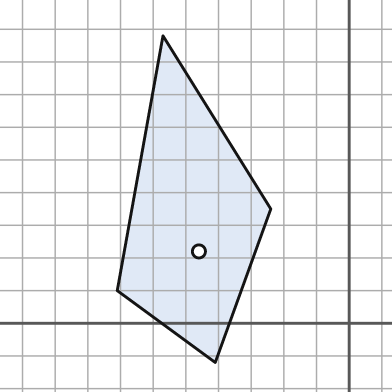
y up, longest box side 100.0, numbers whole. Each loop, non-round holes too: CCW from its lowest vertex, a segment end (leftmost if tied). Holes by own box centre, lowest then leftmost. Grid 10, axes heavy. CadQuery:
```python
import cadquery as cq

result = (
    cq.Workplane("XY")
    .moveTo(-41.0, -12.0)
    .lineTo(-24.0, 35.0)
    .lineTo(-57.0, 88.0)
    .lineTo(-71.0, 10.0)
    .close()
    .moveTo(-46.0, 22.0)
    .circle(2.0)
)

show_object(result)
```